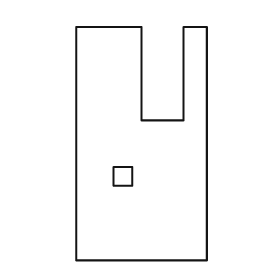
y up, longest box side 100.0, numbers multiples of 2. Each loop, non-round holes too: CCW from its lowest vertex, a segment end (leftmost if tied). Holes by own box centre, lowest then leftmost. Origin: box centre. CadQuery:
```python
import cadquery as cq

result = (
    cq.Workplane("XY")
    .moveTo(-28.0, -50.0)
    .lineTo(28.0, -50.0)
    .lineTo(28.0, 50.0)
    .lineTo(18.0, 50.0)
    .lineTo(18.0, 10.0)
    .lineTo(0.0, 10.0)
    .lineTo(0.0, 50.0)
    .lineTo(-28.0, 50.0)
    .close()
    .moveTo(-12.0, -18.0)
    .lineTo(-4.0, -18.0)
    .lineTo(-4.0, -10.0)
    .lineTo(-12.0, -10.0)
    .close()
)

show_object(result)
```